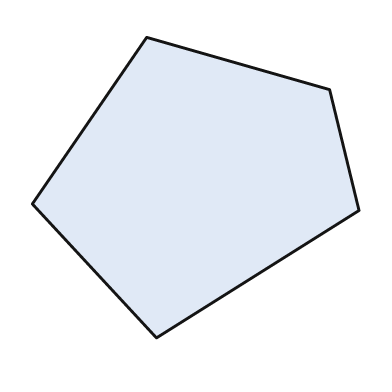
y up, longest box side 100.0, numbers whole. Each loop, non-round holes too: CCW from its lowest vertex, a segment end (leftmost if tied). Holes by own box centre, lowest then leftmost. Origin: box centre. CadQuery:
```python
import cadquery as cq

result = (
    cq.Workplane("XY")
    .moveTo(-12.0, -46.0)
    .lineTo(50.0, -7.0)
    .lineTo(41.0, 30.0)
    .lineTo(-15.0, 46.0)
    .lineTo(-50.0, -5.0)
    .close()
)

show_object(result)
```